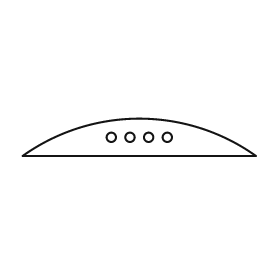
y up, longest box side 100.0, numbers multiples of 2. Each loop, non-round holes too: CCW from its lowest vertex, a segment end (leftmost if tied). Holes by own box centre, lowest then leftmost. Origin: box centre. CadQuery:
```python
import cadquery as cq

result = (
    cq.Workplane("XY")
    .moveTo(-50.0, -8.0)
    .lineTo(50.0, -8.0)
    .threePointArc((0.0, 8.0), (-50.0, -8.0))
    .close()
    .moveTo(-12.0, 0.0)
    .circle(2.0)
    .moveTo(-4.0, 0.0)
    .circle(2.0)
    .moveTo(4.0, 0.0)
    .circle(2.0)
    .moveTo(12.0, 0.0)
    .circle(2.0)
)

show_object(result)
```